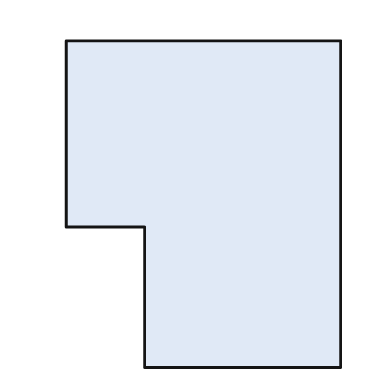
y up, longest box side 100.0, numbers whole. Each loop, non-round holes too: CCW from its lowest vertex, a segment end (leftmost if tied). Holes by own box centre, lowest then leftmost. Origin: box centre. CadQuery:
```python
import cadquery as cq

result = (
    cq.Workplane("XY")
    .moveTo(-18.0, -50.0)
    .lineTo(42.0, -50.0)
    .lineTo(42.0, 50.0)
    .lineTo(-42.0, 50.0)
    .lineTo(-42.0, -7.0)
    .lineTo(-18.0, -7.0)
    .close()
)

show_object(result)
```